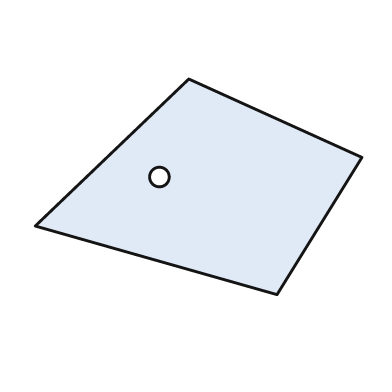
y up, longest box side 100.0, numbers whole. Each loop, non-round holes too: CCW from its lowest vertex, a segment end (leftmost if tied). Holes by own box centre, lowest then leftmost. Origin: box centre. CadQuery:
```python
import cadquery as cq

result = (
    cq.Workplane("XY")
    .moveTo(24.0, -33.0)
    .lineTo(50.0, 9.0)
    .lineTo(-3.0, 33.0)
    .lineTo(-50.0, -12.0)
    .close()
    .moveTo(-12.0, 3.0)
    .circle(3.0)
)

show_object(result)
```